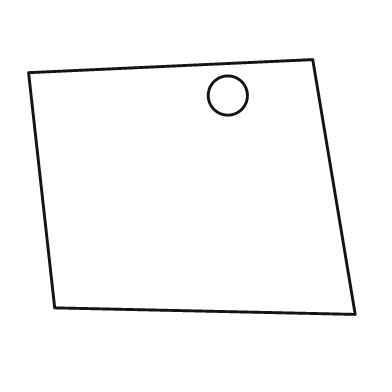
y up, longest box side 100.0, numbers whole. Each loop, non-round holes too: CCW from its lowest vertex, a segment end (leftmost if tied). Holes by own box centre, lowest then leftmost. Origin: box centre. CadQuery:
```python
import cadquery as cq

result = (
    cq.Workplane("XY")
    .moveTo(50.0, -39.0)
    .lineTo(37.0, 39.0)
    .lineTo(-50.0, 35.0)
    .lineTo(-42.0, -37.0)
    .close()
    .moveTo(11.0, 28.0)
    .circle(6.0)
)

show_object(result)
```